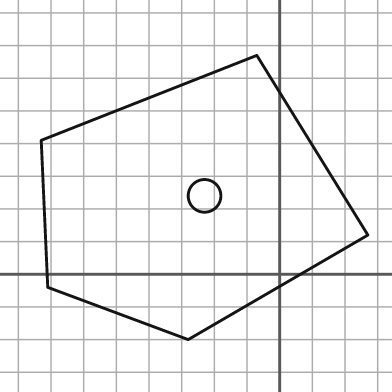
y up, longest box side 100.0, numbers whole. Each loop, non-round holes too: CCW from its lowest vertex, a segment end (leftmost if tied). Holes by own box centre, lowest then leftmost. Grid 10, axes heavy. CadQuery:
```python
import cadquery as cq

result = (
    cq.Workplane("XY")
    .moveTo(-28.0, -20.0)
    .lineTo(27.0, 12.0)
    .lineTo(-7.0, 67.0)
    .lineTo(-73.0, 41.0)
    .lineTo(-71.0, -4.0)
    .close()
    .moveTo(-23.0, 24.0)
    .circle(5.0)
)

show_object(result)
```